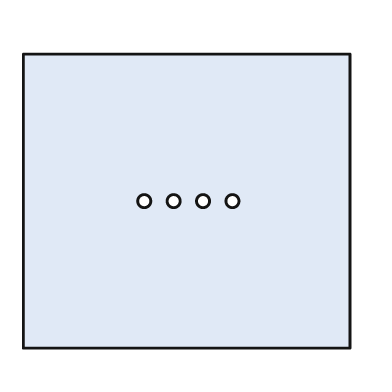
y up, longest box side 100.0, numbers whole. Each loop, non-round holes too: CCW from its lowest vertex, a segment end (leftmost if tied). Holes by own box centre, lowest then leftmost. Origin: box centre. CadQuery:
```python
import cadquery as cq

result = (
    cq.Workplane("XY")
    .moveTo(-50.0, -45.0)
    .lineTo(50.0, -45.0)
    .lineTo(50.0, 45.0)
    .lineTo(-50.0, 45.0)
    .close()
    .moveTo(-13.0, 0.0)
    .circle(2.0)
    .moveTo(-4.0, 0.0)
    .circle(2.0)
    .moveTo(5.0, 0.0)
    .circle(2.0)
    .moveTo(14.0, 0.0)
    .circle(2.0)
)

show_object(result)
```